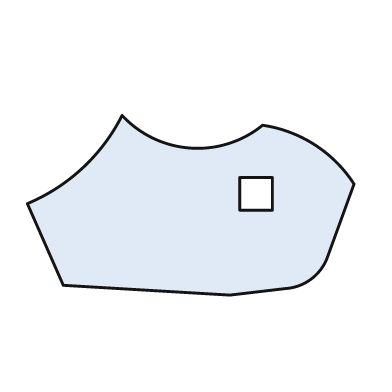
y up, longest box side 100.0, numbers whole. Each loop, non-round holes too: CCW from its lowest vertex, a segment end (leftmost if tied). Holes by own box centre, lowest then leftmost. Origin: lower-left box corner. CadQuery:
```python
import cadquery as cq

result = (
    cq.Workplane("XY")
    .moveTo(62.0, 0.0)
    .lineTo(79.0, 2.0)
    .threePointArc((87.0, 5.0), (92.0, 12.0))
    .lineTo(100.0, 34.0)
    .threePointArc((88.0, 46.0), (72.0, 52.0))
    .threePointArc((50.0, 45.0), (29.0, 55.0))
    .threePointArc((17.0, 39.0), (0.0, 28.0))
    .lineTo(11.0, 3.0)
    .close()
    .moveTo(65.0, 26.0)
    .lineTo(75.0, 26.0)
    .lineTo(75.0, 36.0)
    .lineTo(65.0, 36.0)
    .close()
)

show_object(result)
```